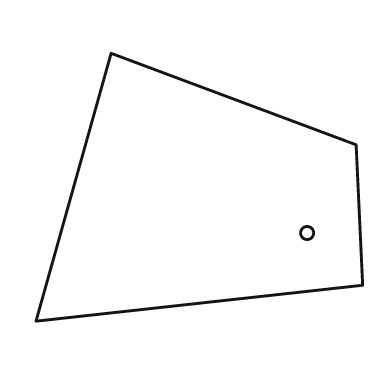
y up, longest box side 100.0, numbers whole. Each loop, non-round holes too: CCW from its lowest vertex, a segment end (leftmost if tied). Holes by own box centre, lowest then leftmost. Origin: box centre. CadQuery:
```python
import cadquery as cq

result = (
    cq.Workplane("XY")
    .moveTo(-50.0, -41.0)
    .lineTo(50.0, -30.0)
    .lineTo(48.0, 13.0)
    .lineTo(-27.0, 41.0)
    .close()
    .moveTo(33.0, -14.0)
    .circle(2.0)
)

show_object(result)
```